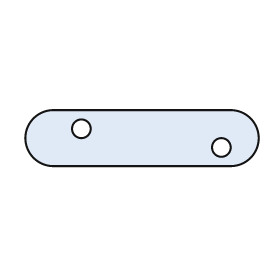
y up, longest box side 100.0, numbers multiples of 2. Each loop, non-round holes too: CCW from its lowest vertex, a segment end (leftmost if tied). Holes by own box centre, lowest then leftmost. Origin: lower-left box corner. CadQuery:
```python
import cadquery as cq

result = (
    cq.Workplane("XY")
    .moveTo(12.0, 0.0)
    .lineTo(88.0, 0.0)
    .threePointArc((100.0, 12.0), (88.0, 24.0))
    .lineTo(12.0, 24.0)
    .threePointArc((0.0, 12.0), (12.0, 0.0))
    .close()
    .moveTo(84.0, 8.0)
    .circle(4.0)
    .moveTo(24.0, 16.0)
    .circle(4.0)
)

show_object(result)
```